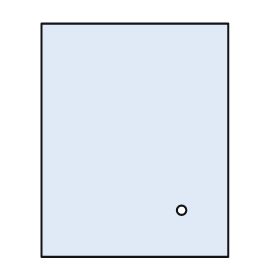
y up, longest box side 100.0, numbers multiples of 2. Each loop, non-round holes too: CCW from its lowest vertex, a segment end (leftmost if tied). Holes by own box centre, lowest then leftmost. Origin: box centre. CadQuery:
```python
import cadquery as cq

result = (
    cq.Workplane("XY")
    .moveTo(-40.0, -50.0)
    .lineTo(40.0, -50.0)
    .lineTo(40.0, 50.0)
    .lineTo(-40.0, 50.0)
    .close()
    .moveTo(20.0, -30.0)
    .circle(2.0)
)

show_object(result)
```